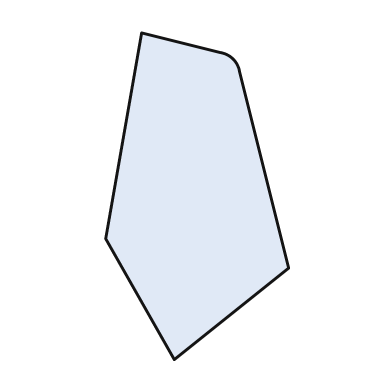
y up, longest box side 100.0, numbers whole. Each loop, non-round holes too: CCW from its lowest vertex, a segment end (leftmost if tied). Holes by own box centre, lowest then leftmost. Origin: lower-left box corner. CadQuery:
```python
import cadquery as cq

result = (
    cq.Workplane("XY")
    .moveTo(21.0, 0.0)
    .lineTo(56.0, 28.0)
    .lineTo(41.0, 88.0)
    .threePointArc((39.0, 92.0), (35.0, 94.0))
    .lineTo(11.0, 100.0)
    .lineTo(0.0, 37.0)
    .close()
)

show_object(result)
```